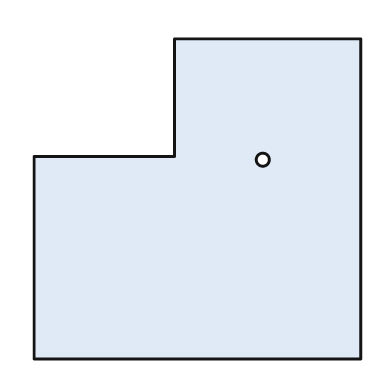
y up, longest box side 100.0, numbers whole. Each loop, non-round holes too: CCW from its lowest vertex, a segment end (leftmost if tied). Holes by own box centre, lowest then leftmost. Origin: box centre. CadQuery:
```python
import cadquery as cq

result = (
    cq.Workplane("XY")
    .moveTo(-50.0, -49.0)
    .lineTo(50.0, -49.0)
    .lineTo(50.0, 49.0)
    .lineTo(-7.0, 49.0)
    .lineTo(-7.0, 13.0)
    .lineTo(-50.0, 13.0)
    .close()
    .moveTo(20.0, 12.0)
    .circle(2.0)
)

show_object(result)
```